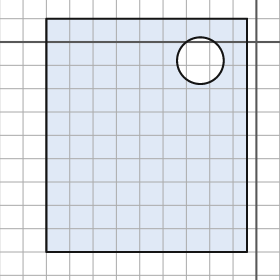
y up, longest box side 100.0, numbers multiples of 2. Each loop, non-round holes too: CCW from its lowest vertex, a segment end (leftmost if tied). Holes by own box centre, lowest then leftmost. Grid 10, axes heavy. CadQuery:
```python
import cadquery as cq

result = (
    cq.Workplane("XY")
    .moveTo(-90.0, -90.0)
    .lineTo(-4.0, -90.0)
    .lineTo(-4.0, 10.0)
    .lineTo(-90.0, 10.0)
    .close()
    .moveTo(-24.0, -8.0)
    .circle(10.0)
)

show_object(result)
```